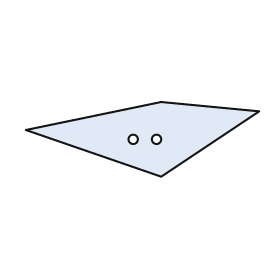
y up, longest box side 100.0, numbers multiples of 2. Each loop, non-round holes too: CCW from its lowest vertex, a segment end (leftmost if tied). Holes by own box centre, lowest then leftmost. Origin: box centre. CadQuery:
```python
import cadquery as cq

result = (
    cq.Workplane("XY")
    .moveTo(8.0, -16.0)
    .lineTo(50.0, 12.0)
    .lineTo(8.0, 16.0)
    .lineTo(-50.0, 4.0)
    .close()
    .moveTo(-4.0, 0.0)
    .circle(2.0)
    .moveTo(6.0, 0.0)
    .circle(2.0)
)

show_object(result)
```